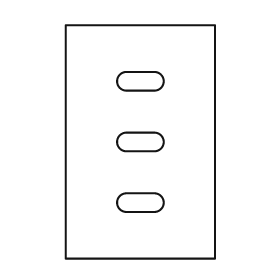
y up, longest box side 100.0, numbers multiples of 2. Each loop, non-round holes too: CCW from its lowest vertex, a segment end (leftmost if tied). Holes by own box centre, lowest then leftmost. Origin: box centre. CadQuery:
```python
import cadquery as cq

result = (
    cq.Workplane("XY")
    .moveTo(-32.0, -50.0)
    .lineTo(32.0, -50.0)
    .lineTo(32.0, 50.0)
    .lineTo(-32.0, 50.0)
    .close()
    .moveTo(-6.0, -30.0)
    .lineTo(6.0, -30.0)
    .threePointArc((10.0, -26.0), (6.0, -22.0))
    .lineTo(-6.0, -22.0)
    .threePointArc((-10.0, -26.0), (-6.0, -30.0))
    .close()
    .moveTo(-6.0, -4.0)
    .lineTo(6.0, -4.0)
    .threePointArc((10.0, 0.0), (6.0, 4.0))
    .lineTo(-6.0, 4.0)
    .threePointArc((-10.0, 0.0), (-6.0, -4.0))
    .close()
    .moveTo(-6.0, 22.0)
    .lineTo(6.0, 22.0)
    .threePointArc((10.0, 26.0), (6.0, 30.0))
    .lineTo(-6.0, 30.0)
    .threePointArc((-10.0, 26.0), (-6.0, 22.0))
    .close()
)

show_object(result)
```